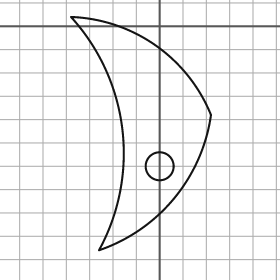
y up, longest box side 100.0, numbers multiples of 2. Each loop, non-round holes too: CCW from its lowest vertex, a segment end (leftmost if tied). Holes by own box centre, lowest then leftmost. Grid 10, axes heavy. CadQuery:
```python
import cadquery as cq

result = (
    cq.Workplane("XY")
    .moveTo(-26.0, -96.0)
    .threePointArc((6.0, -74.0), (22.0, -38.0))
    .threePointArc((-2.0, -8.0), (-38.0, 4.0))
    .threePointArc((-16.0, -44.0), (-26.0, -96.0))
    .close()
    .moveTo(0.0, -60.0)
    .circle(6.0)
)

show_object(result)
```